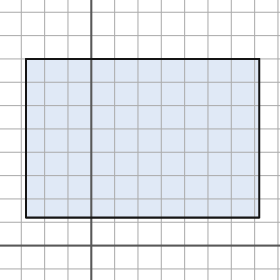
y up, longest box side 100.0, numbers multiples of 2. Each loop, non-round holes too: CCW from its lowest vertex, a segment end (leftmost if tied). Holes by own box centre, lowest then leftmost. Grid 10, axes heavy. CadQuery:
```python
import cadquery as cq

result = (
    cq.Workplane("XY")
    .moveTo(-28.0, 12.0)
    .lineTo(72.0, 12.0)
    .lineTo(72.0, 80.0)
    .lineTo(-28.0, 80.0)
    .close()
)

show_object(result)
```